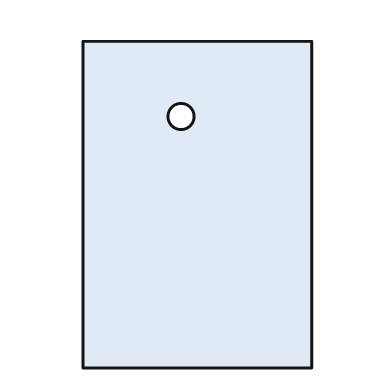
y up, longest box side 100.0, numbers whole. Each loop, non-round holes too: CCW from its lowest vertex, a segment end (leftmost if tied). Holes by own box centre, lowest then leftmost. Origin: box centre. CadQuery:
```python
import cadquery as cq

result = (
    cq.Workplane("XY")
    .moveTo(-35.0, -50.0)
    .lineTo(35.0, -50.0)
    .lineTo(35.0, 50.0)
    .lineTo(-35.0, 50.0)
    .close()
    .moveTo(-5.0, 27.0)
    .circle(4.0)
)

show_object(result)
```